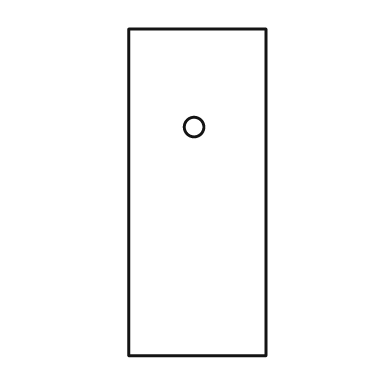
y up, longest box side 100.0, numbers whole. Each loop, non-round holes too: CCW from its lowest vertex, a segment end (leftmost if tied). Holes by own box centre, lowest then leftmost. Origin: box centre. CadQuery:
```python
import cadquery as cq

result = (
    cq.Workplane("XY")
    .moveTo(-21.0, -50.0)
    .lineTo(21.0, -50.0)
    .lineTo(21.0, 50.0)
    .lineTo(-21.0, 50.0)
    .close()
    .moveTo(-1.0, 20.0)
    .circle(3.0)
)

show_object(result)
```